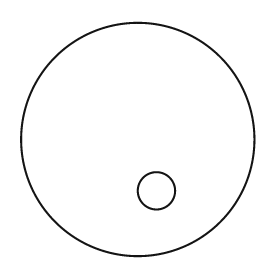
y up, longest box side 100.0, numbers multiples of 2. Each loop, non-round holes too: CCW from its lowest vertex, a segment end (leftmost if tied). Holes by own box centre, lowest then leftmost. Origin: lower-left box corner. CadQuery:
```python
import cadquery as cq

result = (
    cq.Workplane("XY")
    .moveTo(50.0, 50.0)
    .circle(50.0)
    .moveTo(58.0, 28.0)
    .circle(8.0)
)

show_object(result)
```